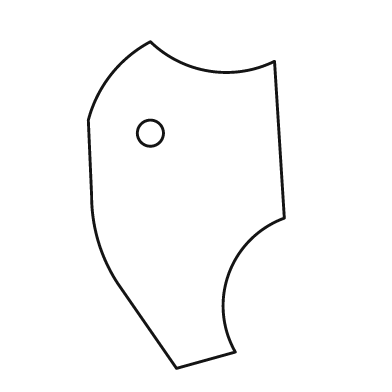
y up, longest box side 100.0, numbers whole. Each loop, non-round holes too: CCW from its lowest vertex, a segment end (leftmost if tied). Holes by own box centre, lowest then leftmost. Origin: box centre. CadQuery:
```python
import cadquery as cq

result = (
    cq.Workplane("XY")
    .moveTo(-3.0, -50.0)
    .lineTo(15.0, -45.0)
    .threePointArc((13.0, -21.0), (30.0, -4.0))
    .lineTo(27.0, 44.0)
    .threePointArc((7.0, 41.0), (-11.0, 50.0))
    .threePointArc((-23.0, 40.0), (-30.0, 26.0))
    .lineTo(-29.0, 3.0)
    .threePointArc((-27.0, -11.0), (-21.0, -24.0))
    .close()
    .moveTo(-11.0, 22.0)
    .circle(4.0)
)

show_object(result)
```